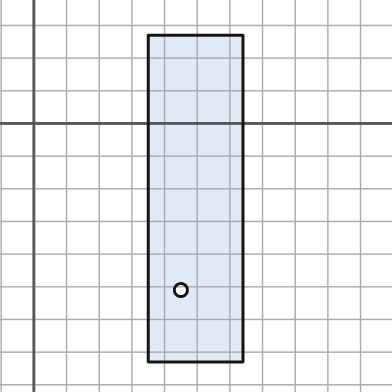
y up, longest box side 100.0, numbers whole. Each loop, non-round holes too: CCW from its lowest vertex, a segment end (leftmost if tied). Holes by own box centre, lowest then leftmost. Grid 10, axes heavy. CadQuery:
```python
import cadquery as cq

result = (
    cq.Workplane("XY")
    .moveTo(35.0, -73.0)
    .lineTo(64.0, -73.0)
    .lineTo(64.0, 27.0)
    .lineTo(35.0, 27.0)
    .close()
    .moveTo(45.0, -51.0)
    .circle(2.0)
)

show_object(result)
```